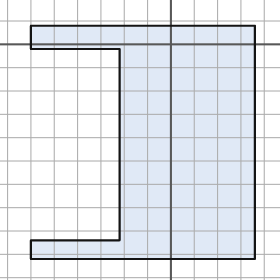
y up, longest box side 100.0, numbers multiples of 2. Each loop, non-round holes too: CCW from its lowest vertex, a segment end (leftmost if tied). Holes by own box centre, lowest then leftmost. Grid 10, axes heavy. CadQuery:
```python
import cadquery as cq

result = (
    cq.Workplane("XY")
    .moveTo(-60.0, -92.0)
    .lineTo(36.0, -92.0)
    .lineTo(36.0, 8.0)
    .lineTo(-60.0, 8.0)
    .lineTo(-60.0, -2.0)
    .lineTo(-22.0, -2.0)
    .lineTo(-22.0, -84.0)
    .lineTo(-60.0, -84.0)
    .close()
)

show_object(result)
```